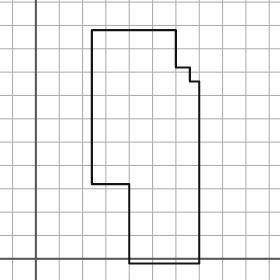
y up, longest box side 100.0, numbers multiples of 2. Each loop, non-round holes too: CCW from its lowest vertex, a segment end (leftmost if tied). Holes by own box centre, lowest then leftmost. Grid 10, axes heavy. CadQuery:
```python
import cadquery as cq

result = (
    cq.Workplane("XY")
    .moveTo(40.0, -2.0)
    .lineTo(70.0, -2.0)
    .lineTo(70.0, 76.0)
    .lineTo(66.0, 76.0)
    .lineTo(66.0, 82.0)
    .lineTo(60.0, 82.0)
    .lineTo(60.0, 98.0)
    .lineTo(24.0, 98.0)
    .lineTo(24.0, 32.0)
    .lineTo(40.0, 32.0)
    .close()
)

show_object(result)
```